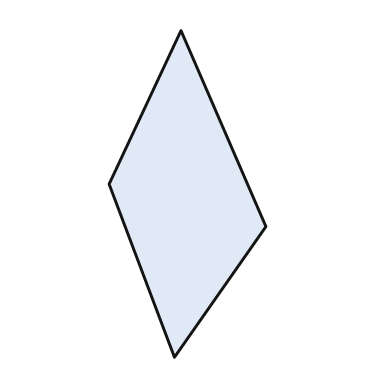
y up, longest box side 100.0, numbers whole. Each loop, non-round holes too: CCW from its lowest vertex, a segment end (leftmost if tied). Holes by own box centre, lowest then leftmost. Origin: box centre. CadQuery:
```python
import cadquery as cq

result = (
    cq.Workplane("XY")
    .moveTo(-4.0, -50.0)
    .lineTo(24.0, -10.0)
    .lineTo(-2.0, 50.0)
    .lineTo(-24.0, 3.0)
    .close()
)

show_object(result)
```